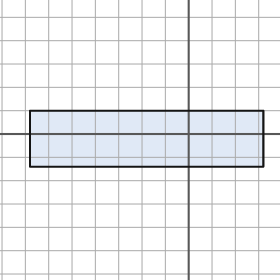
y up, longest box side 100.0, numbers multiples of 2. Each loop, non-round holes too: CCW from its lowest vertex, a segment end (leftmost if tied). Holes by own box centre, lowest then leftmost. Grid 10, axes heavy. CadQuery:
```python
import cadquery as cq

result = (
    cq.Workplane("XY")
    .moveTo(-68.0, -14.0)
    .lineTo(32.0, -14.0)
    .lineTo(32.0, 10.0)
    .lineTo(-68.0, 10.0)
    .close()
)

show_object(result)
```